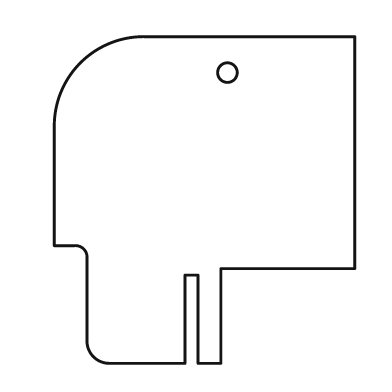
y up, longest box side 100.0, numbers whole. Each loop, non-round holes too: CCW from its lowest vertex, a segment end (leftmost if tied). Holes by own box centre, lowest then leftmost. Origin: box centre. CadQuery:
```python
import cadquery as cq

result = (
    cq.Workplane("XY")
    .moveTo(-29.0, -50.0)
    .lineTo(-6.0, -50.0)
    .lineTo(-6.0, -23.0)
    .lineTo(-2.0, -23.0)
    .lineTo(-2.0, -50.0)
    .lineTo(5.0, -50.0)
    .lineTo(5.0, -21.0)
    .lineTo(46.0, -21.0)
    .lineTo(46.0, 50.0)
    .lineTo(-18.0, 50.0)
    .threePointArc((-38.0, 42.0), (-46.0, 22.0))
    .lineTo(-46.0, -14.0)
    .lineTo(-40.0, -14.0)
    .threePointArc((-37.0, -15.0), (-36.0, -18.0))
    .lineTo(-36.0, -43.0)
    .threePointArc((-34.0, -48.0), (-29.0, -50.0))
    .close()
    .moveTo(7.0, 39.0)
    .circle(3.0)
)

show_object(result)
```